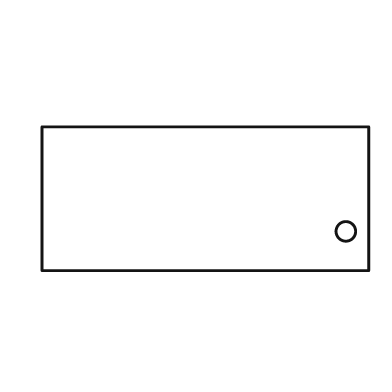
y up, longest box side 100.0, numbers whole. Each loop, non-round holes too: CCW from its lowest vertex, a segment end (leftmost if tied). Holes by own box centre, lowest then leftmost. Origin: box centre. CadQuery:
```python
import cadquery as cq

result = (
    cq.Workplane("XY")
    .moveTo(-50.0, -22.0)
    .lineTo(50.0, -22.0)
    .lineTo(50.0, 22.0)
    .lineTo(-50.0, 22.0)
    .close()
    .moveTo(43.0, -10.0)
    .circle(3.0)
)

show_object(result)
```